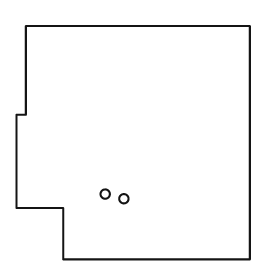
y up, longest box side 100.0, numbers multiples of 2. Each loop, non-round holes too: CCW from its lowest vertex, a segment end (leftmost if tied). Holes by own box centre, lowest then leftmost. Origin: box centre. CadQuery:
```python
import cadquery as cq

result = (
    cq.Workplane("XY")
    .moveTo(-30.0, -50.0)
    .lineTo(50.0, -50.0)
    .lineTo(50.0, 50.0)
    .lineTo(-46.0, 50.0)
    .lineTo(-46.0, 12.0)
    .lineTo(-50.0, 12.0)
    .lineTo(-50.0, -28.0)
    .lineTo(-30.0, -28.0)
    .close()
    .moveTo(-4.0, -24.0)
    .circle(2.0)
    .moveTo(-12.0, -22.0)
    .circle(2.0)
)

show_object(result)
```